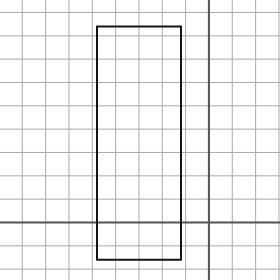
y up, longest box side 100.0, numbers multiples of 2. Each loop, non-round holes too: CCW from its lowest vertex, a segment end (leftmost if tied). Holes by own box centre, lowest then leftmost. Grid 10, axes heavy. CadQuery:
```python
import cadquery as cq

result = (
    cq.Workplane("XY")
    .moveTo(-48.0, -16.0)
    .lineTo(-12.0, -16.0)
    .lineTo(-12.0, 84.0)
    .lineTo(-48.0, 84.0)
    .close()
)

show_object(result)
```